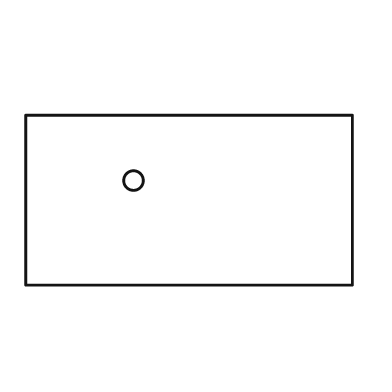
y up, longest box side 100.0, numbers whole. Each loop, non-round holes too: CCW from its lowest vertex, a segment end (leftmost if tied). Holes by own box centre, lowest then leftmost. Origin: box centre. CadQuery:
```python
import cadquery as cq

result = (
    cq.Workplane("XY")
    .moveTo(-50.0, -26.0)
    .lineTo(50.0, -26.0)
    .lineTo(50.0, 26.0)
    .lineTo(-50.0, 26.0)
    .close()
    .moveTo(-17.0, 6.0)
    .circle(3.0)
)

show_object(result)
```